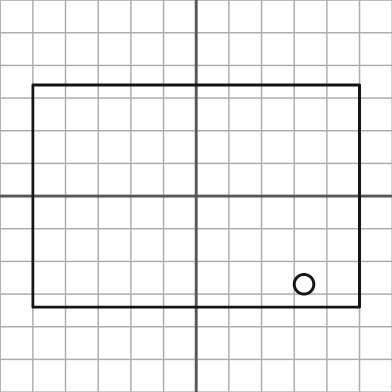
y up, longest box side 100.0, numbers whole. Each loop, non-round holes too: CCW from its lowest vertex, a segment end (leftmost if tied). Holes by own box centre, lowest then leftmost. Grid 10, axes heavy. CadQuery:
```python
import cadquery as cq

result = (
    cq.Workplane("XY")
    .moveTo(-50.0, -34.0)
    .lineTo(50.0, -34.0)
    .lineTo(50.0, 34.0)
    .lineTo(-50.0, 34.0)
    .close()
    .moveTo(33.0, -27.0)
    .circle(3.0)
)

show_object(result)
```